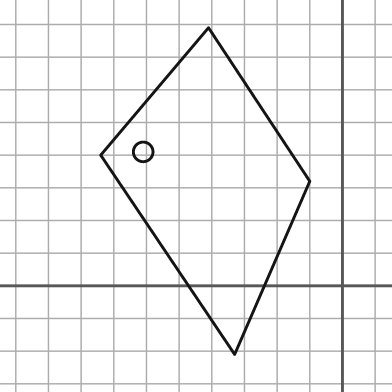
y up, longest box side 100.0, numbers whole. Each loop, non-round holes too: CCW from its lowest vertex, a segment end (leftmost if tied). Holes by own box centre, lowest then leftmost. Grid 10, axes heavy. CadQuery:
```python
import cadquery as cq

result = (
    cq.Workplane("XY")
    .moveTo(-33.0, -21.0)
    .lineTo(-10.0, 32.0)
    .lineTo(-41.0, 79.0)
    .lineTo(-74.0, 40.0)
    .close()
    .moveTo(-61.0, 41.0)
    .circle(3.0)
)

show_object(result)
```